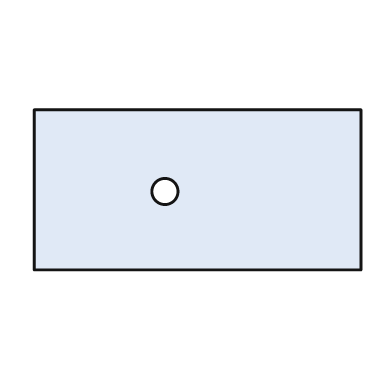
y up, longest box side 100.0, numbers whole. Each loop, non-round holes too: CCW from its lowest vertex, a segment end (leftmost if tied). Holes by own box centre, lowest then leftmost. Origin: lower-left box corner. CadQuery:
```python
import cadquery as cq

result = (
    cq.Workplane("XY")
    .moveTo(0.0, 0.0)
    .lineTo(100.0, 0.0)
    .lineTo(100.0, 49.0)
    .lineTo(0.0, 49.0)
    .close()
    .moveTo(40.0, 24.0)
    .circle(4.0)
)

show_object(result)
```